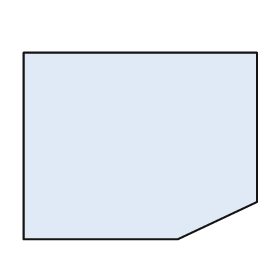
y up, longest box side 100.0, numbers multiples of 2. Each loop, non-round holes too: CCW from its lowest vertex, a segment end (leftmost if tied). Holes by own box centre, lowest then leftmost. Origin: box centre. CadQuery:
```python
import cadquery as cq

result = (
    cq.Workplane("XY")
    .moveTo(-50.0, -40.0)
    .lineTo(16.0, -40.0)
    .lineTo(50.0, -24.0)
    .lineTo(50.0, 40.0)
    .lineTo(-50.0, 40.0)
    .close()
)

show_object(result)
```